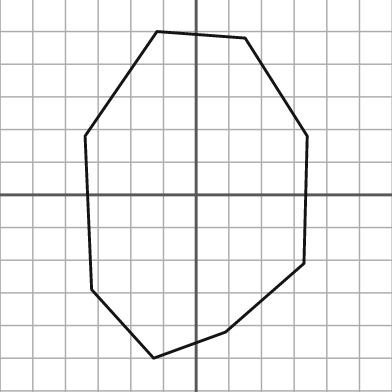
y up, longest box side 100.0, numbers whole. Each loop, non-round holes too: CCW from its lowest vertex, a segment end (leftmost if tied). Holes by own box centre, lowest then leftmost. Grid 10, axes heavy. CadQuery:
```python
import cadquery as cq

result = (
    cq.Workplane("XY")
    .moveTo(-13.0, -50.0)
    .lineTo(9.0, -42.0)
    .lineTo(33.0, -21.0)
    .lineTo(34.0, 18.0)
    .lineTo(15.0, 48.0)
    .lineTo(-12.0, 50.0)
    .lineTo(-34.0, 18.0)
    .lineTo(-32.0, -29.0)
    .close()
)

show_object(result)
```